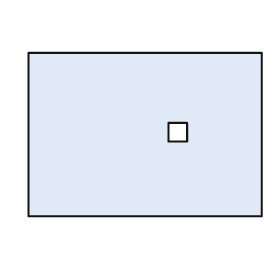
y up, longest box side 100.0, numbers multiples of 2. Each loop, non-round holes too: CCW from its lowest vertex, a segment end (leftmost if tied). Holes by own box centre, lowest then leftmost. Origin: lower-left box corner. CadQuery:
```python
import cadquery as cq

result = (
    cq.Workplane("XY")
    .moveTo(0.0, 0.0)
    .lineTo(100.0, 0.0)
    .lineTo(100.0, 70.0)
    .lineTo(0.0, 70.0)
    .close()
    .moveTo(60.0, 32.0)
    .lineTo(68.0, 32.0)
    .lineTo(68.0, 40.0)
    .lineTo(60.0, 40.0)
    .close()
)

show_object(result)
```